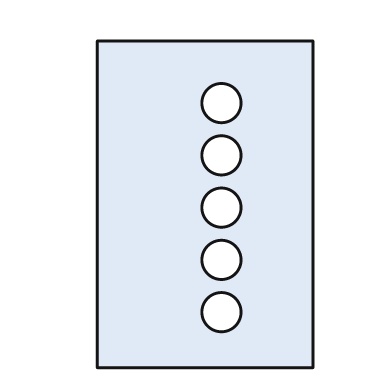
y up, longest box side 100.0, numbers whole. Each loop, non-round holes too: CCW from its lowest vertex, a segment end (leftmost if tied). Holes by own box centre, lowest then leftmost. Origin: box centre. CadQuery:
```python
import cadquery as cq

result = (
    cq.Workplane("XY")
    .moveTo(-33.0, -50.0)
    .lineTo(33.0, -50.0)
    .lineTo(33.0, 50.0)
    .lineTo(-33.0, 50.0)
    .close()
    .moveTo(5.0, -33.0)
    .circle(6.0)
    .moveTo(5.0, -17.0)
    .circle(6.0)
    .moveTo(5.0, -1.0)
    .circle(6.0)
    .moveTo(5.0, 15.0)
    .circle(6.0)
    .moveTo(5.0, 31.0)
    .circle(6.0)
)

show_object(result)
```